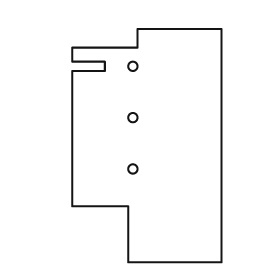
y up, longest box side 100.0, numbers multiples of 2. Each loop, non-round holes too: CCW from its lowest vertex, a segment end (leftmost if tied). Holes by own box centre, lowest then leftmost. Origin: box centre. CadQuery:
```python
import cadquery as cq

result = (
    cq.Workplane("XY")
    .moveTo(-8.0, -50.0)
    .lineTo(32.0, -50.0)
    .lineTo(32.0, 50.0)
    .lineTo(-4.0, 50.0)
    .lineTo(-4.0, 42.0)
    .lineTo(-32.0, 42.0)
    .lineTo(-32.0, 36.0)
    .lineTo(-18.0, 36.0)
    .lineTo(-18.0, 32.0)
    .lineTo(-32.0, 32.0)
    .lineTo(-32.0, -26.0)
    .lineTo(-8.0, -26.0)
    .close()
    .moveTo(-6.0, -10.0)
    .circle(2.0)
    .moveTo(-6.0, 12.0)
    .circle(2.0)
    .moveTo(-6.0, 34.0)
    .circle(2.0)
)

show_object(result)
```